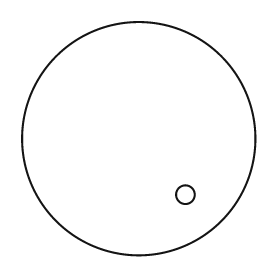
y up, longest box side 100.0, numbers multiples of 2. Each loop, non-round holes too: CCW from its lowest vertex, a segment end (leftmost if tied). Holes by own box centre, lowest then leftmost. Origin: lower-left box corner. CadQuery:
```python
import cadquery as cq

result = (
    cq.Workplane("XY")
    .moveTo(50.0, 50.0)
    .circle(50.0)
    .moveTo(70.0, 26.0)
    .circle(4.0)
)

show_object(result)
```